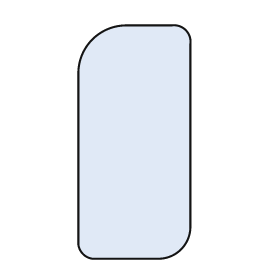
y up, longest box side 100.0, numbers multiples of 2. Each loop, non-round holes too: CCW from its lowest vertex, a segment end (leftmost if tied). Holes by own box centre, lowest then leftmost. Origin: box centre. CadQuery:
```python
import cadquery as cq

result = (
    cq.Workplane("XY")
    .moveTo(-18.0, -50.0)
    .lineTo(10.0, -50.0)
    .threePointArc((20.0, -46.0), (24.0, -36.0))
    .lineTo(24.0, 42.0)
    .threePointArc((22.0, 48.0), (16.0, 50.0))
    .lineTo(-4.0, 50.0)
    .threePointArc((-18.0, 44.0), (-24.0, 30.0))
    .lineTo(-24.0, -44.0)
    .threePointArc((-22.0, -48.0), (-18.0, -50.0))
    .close()
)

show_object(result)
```